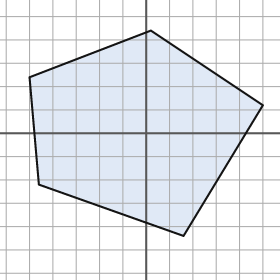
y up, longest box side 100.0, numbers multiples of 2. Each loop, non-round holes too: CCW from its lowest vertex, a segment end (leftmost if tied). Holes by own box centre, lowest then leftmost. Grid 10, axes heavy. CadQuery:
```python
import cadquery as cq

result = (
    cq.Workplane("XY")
    .moveTo(16.0, -44.0)
    .lineTo(50.0, 12.0)
    .lineTo(2.0, 44.0)
    .lineTo(-50.0, 24.0)
    .lineTo(-46.0, -22.0)
    .close()
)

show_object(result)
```